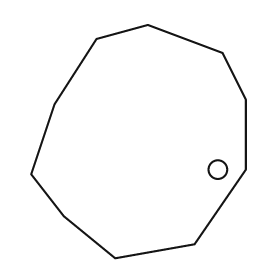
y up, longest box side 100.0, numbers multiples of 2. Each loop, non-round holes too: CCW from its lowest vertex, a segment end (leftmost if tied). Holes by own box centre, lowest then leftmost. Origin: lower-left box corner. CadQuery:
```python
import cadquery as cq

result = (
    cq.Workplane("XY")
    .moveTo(36.0, 0.0)
    .lineTo(70.0, 6.0)
    .lineTo(92.0, 38.0)
    .lineTo(92.0, 68.0)
    .lineTo(82.0, 88.0)
    .lineTo(50.0, 100.0)
    .lineTo(28.0, 94.0)
    .lineTo(10.0, 66.0)
    .lineTo(0.0, 36.0)
    .lineTo(14.0, 18.0)
    .close()
    .moveTo(80.0, 38.0)
    .circle(4.0)
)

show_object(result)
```